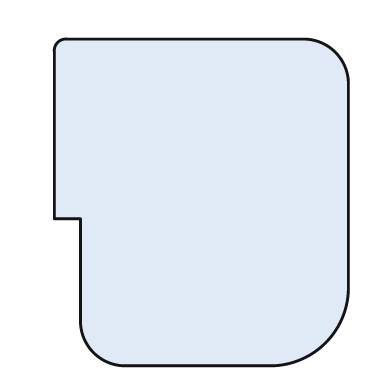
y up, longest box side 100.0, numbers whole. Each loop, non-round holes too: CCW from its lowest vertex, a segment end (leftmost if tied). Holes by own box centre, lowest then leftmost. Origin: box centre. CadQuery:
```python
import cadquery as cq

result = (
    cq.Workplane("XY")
    .moveTo(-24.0, -50.0)
    .lineTo(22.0, -50.0)
    .threePointArc((38.0, -43.0), (45.0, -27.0))
    .lineTo(45.0, 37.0)
    .threePointArc((41.0, 46.0), (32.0, 50.0))
    .lineTo(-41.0, 50.0)
    .threePointArc((-44.0, 49.0), (-45.0, 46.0))
    .lineTo(-45.0, -5.0)
    .lineTo(-37.0, -5.0)
    .lineTo(-37.0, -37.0)
    .threePointArc((-33.0, -46.0), (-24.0, -50.0))
    .close()
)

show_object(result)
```